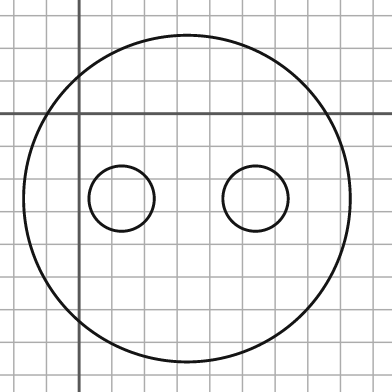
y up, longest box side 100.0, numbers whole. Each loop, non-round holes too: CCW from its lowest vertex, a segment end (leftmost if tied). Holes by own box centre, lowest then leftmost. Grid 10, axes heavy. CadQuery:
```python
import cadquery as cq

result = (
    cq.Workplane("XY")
    .moveTo(33.0, -26.0)
    .circle(50.0)
    .moveTo(13.0, -26.0)
    .circle(10.0)
    .moveTo(54.0, -26.0)
    .circle(10.0)
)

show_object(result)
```